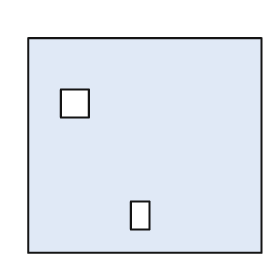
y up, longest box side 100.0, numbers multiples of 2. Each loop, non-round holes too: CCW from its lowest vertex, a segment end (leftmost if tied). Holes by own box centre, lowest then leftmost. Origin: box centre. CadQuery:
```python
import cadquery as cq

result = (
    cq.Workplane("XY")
    .moveTo(-50.0, -46.0)
    .lineTo(50.0, -46.0)
    .lineTo(50.0, 46.0)
    .lineTo(-50.0, 46.0)
    .close()
    .moveTo(-6.0, -36.0)
    .lineTo(2.0, -36.0)
    .lineTo(2.0, -24.0)
    .lineTo(-6.0, -24.0)
    .close()
    .moveTo(-36.0, 12.0)
    .lineTo(-24.0, 12.0)
    .lineTo(-24.0, 24.0)
    .lineTo(-36.0, 24.0)
    .close()
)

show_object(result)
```